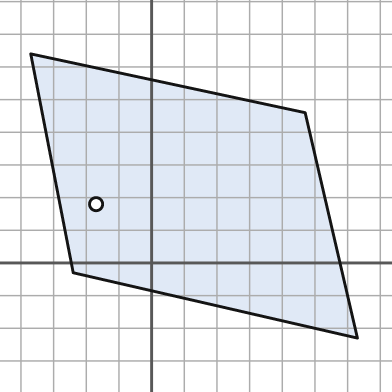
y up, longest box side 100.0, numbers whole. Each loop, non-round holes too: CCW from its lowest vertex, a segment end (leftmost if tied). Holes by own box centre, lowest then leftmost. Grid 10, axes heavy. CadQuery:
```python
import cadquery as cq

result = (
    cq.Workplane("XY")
    .moveTo(63.0, -23.0)
    .lineTo(47.0, 46.0)
    .lineTo(-37.0, 64.0)
    .lineTo(-24.0, -3.0)
    .close()
    .moveTo(-17.0, 18.0)
    .circle(2.0)
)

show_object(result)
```